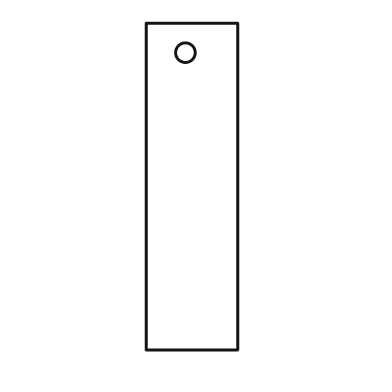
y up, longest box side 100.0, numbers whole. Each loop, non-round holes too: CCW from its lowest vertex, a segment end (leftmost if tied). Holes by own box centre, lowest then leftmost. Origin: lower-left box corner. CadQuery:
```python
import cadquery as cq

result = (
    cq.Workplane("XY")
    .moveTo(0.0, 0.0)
    .lineTo(28.0, 0.0)
    .lineTo(28.0, 100.0)
    .lineTo(0.0, 100.0)
    .close()
    .moveTo(12.0, 91.0)
    .circle(3.0)
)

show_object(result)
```